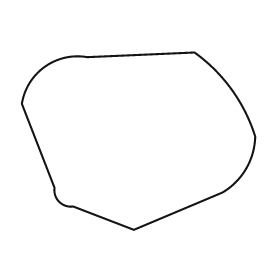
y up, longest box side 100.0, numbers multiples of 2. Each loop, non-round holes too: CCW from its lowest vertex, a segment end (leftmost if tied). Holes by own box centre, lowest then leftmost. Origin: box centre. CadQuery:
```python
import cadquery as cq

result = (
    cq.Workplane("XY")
    .moveTo(-2.0, -38.0)
    .lineTo(36.0, -22.0)
    .threePointArc((46.0, -12.0), (50.0, 2.0))
    .threePointArc((40.0, 22.0), (24.0, 38.0))
    .lineTo(-22.0, 36.0)
    .threePointArc((-40.0, 32.0), (-50.0, 16.0))
    .lineTo(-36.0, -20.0)
    .threePointArc((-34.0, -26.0), (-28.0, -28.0))
    .close()
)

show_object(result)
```